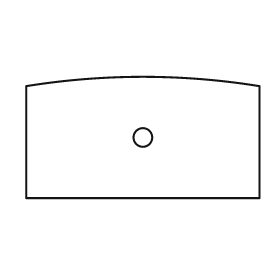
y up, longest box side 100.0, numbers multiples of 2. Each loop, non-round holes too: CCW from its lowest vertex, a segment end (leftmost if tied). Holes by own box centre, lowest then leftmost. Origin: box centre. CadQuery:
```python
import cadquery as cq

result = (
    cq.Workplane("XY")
    .moveTo(-50.0, -26.0)
    .lineTo(50.0, -26.0)
    .lineTo(50.0, 22.0)
    .threePointArc((0.0, 26.0), (-50.0, 22.0))
    .close()
    .moveTo(0.0, 0.0)
    .circle(4.0)
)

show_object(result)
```